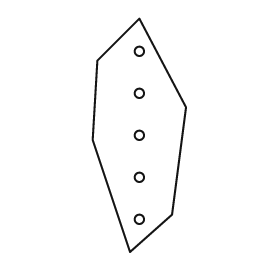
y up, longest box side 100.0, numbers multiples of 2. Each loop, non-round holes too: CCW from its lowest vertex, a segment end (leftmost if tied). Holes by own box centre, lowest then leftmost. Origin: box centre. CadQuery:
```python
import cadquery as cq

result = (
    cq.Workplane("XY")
    .moveTo(-4.0, -50.0)
    .lineTo(14.0, -34.0)
    .lineTo(20.0, 12.0)
    .lineTo(0.0, 50.0)
    .lineTo(-18.0, 32.0)
    .lineTo(-20.0, -2.0)
    .close()
    .moveTo(0.0, -36.0)
    .circle(2.0)
    .moveTo(0.0, -18.0)
    .circle(2.0)
    .moveTo(0.0, 0.0)
    .circle(2.0)
    .moveTo(0.0, 18.0)
    .circle(2.0)
    .moveTo(0.0, 36.0)
    .circle(2.0)
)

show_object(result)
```